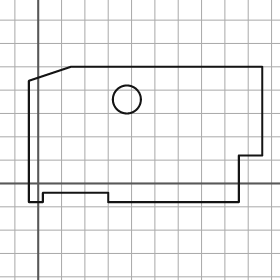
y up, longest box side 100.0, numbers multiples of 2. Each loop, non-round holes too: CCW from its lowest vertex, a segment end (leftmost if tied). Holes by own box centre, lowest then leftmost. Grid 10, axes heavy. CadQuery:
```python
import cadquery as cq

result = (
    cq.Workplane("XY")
    .moveTo(-4.0, -8.0)
    .lineTo(2.0, -8.0)
    .lineTo(2.0, -4.0)
    .lineTo(30.0, -4.0)
    .lineTo(30.0, -8.0)
    .lineTo(86.0, -8.0)
    .lineTo(86.0, 12.0)
    .lineTo(96.0, 12.0)
    .lineTo(96.0, 50.0)
    .lineTo(14.0, 50.0)
    .lineTo(-4.0, 44.0)
    .close()
    .moveTo(38.0, 36.0)
    .circle(6.0)
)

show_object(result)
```